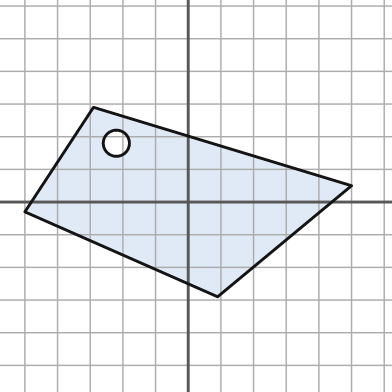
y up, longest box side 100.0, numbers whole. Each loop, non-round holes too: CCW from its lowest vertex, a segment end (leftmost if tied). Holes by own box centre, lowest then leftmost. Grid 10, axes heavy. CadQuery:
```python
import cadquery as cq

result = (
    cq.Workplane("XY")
    .moveTo(9.0, -29.0)
    .lineTo(50.0, 5.0)
    .lineTo(-29.0, 29.0)
    .lineTo(-50.0, -3.0)
    .close()
    .moveTo(-22.0, 18.0)
    .circle(4.0)
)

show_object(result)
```